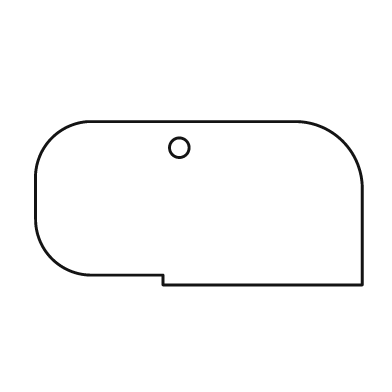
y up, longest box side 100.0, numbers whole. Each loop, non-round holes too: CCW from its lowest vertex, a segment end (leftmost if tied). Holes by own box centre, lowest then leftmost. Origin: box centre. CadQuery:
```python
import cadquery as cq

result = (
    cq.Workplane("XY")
    .moveTo(-11.0, -25.0)
    .lineTo(50.0, -25.0)
    .lineTo(50.0, 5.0)
    .threePointArc((44.0, 19.0), (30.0, 25.0))
    .lineTo(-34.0, 25.0)
    .threePointArc((-45.0, 20.0), (-50.0, 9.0))
    .lineTo(-50.0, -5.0)
    .threePointArc((-45.0, -17.0), (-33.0, -22.0))
    .lineTo(-11.0, -22.0)
    .close()
    .moveTo(-6.0, 17.0)
    .circle(3.0)
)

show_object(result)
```